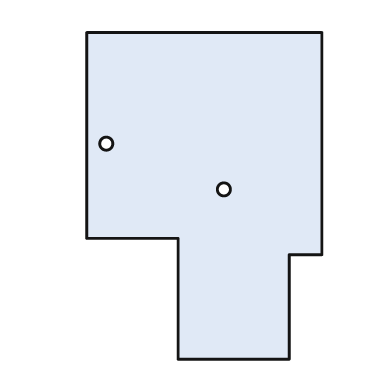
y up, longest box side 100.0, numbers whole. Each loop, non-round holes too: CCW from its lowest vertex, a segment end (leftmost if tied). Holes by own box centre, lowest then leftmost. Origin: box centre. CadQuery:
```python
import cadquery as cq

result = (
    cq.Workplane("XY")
    .moveTo(-8.0, -50.0)
    .lineTo(26.0, -50.0)
    .lineTo(26.0, -18.0)
    .lineTo(36.0, -18.0)
    .lineTo(36.0, 50.0)
    .lineTo(-36.0, 50.0)
    .lineTo(-36.0, -13.0)
    .lineTo(-8.0, -13.0)
    .close()
    .moveTo(6.0, 2.0)
    .circle(2.0)
    .moveTo(-30.0, 16.0)
    .circle(2.0)
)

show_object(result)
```